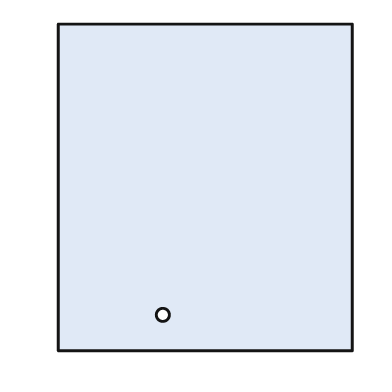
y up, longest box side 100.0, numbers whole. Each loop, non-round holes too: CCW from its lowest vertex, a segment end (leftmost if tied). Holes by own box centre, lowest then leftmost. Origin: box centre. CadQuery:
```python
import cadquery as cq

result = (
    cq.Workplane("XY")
    .moveTo(-45.0, -50.0)
    .lineTo(45.0, -50.0)
    .lineTo(45.0, 50.0)
    .lineTo(-45.0, 50.0)
    .close()
    .moveTo(-13.0, -39.0)
    .circle(2.0)
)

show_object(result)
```